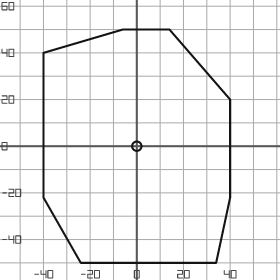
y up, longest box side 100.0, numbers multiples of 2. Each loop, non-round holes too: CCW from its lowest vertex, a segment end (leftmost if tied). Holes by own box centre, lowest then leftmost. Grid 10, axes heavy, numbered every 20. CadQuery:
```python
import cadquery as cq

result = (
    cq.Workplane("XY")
    .moveTo(-24.0, -50.0)
    .lineTo(34.0, -50.0)
    .lineTo(40.0, -22.0)
    .lineTo(40.0, 20.0)
    .lineTo(14.0, 50.0)
    .lineTo(-6.0, 50.0)
    .lineTo(-40.0, 40.0)
    .lineTo(-40.0, -22.0)
    .close()
    .moveTo(0.0, 0.0)
    .circle(2.0)
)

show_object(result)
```